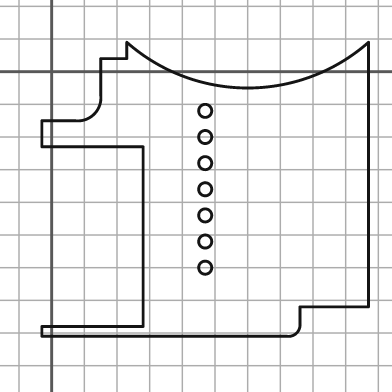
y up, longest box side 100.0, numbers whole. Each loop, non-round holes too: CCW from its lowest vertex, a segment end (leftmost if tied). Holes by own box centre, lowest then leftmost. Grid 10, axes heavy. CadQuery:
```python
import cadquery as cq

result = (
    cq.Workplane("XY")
    .moveTo(-3.0, -81.0)
    .lineTo(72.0, -81.0)
    .threePointArc((75.0, -80.0), (76.0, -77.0))
    .lineTo(76.0, -72.0)
    .lineTo(97.0, -72.0)
    .lineTo(97.0, 9.0)
    .threePointArc((60.0, -5.0), (23.0, 9.0))
    .lineTo(23.0, 4.0)
    .lineTo(15.0, 4.0)
    .lineTo(15.0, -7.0)
    .threePointArc((13.0, -13.0), (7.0, -15.0))
    .lineTo(-3.0, -15.0)
    .lineTo(-3.0, -23.0)
    .lineTo(28.0, -23.0)
    .lineTo(28.0, -78.0)
    .lineTo(-3.0, -78.0)
    .close()
    .moveTo(47.0, -60.0)
    .circle(2.0)
    .moveTo(47.0, -52.0)
    .circle(2.0)
    .moveTo(47.0, -44.0)
    .circle(2.0)
    .moveTo(47.0, -36.0)
    .circle(2.0)
    .moveTo(47.0, -28.0)
    .circle(2.0)
    .moveTo(47.0, -20.0)
    .circle(2.0)
    .moveTo(47.0, -12.0)
    .circle(2.0)
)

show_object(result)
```